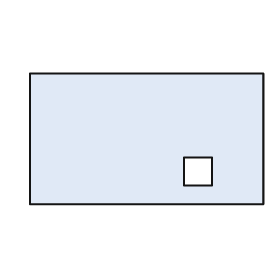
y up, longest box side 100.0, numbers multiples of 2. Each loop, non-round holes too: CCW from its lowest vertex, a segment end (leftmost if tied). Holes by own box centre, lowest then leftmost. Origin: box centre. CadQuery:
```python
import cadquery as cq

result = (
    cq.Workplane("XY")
    .moveTo(-50.0, -28.0)
    .lineTo(50.0, -28.0)
    .lineTo(50.0, 28.0)
    .lineTo(-50.0, 28.0)
    .close()
    .moveTo(16.0, -20.0)
    .lineTo(28.0, -20.0)
    .lineTo(28.0, -8.0)
    .lineTo(16.0, -8.0)
    .close()
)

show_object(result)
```